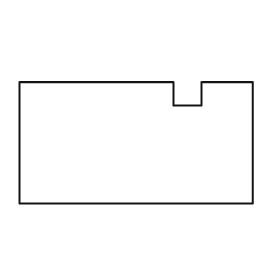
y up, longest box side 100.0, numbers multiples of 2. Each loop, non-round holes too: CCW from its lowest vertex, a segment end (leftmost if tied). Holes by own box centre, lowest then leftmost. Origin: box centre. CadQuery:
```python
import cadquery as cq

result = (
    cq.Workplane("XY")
    .moveTo(-50.0, -26.0)
    .lineTo(50.0, -26.0)
    .lineTo(50.0, 26.0)
    .lineTo(28.0, 26.0)
    .lineTo(28.0, 16.0)
    .lineTo(16.0, 16.0)
    .lineTo(16.0, 26.0)
    .lineTo(-50.0, 26.0)
    .close()
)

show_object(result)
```